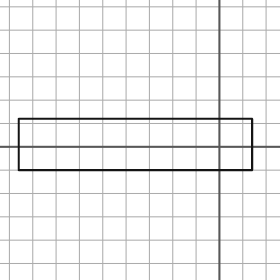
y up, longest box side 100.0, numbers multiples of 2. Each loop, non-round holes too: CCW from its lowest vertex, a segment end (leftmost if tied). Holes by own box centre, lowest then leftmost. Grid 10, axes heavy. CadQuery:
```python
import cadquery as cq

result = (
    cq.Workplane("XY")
    .moveTo(-86.0, -10.0)
    .lineTo(14.0, -10.0)
    .lineTo(14.0, 12.0)
    .lineTo(-86.0, 12.0)
    .close()
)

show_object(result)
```